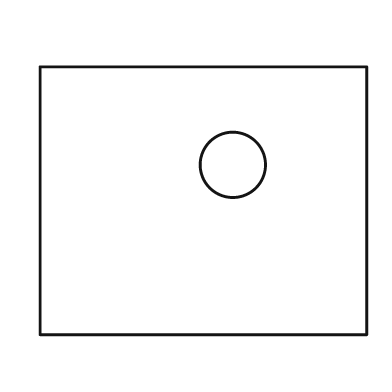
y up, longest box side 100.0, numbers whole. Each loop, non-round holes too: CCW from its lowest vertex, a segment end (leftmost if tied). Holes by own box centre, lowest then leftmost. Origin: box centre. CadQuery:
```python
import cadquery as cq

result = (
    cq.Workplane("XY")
    .moveTo(-50.0, -41.0)
    .lineTo(50.0, -41.0)
    .lineTo(50.0, 41.0)
    .lineTo(-50.0, 41.0)
    .close()
    .moveTo(9.0, 11.0)
    .circle(10.0)
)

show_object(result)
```